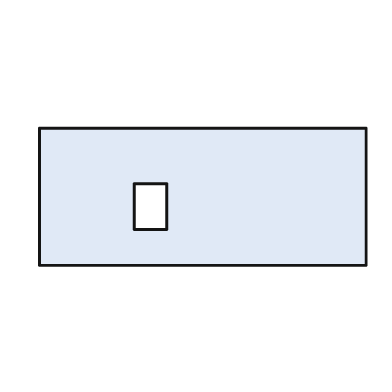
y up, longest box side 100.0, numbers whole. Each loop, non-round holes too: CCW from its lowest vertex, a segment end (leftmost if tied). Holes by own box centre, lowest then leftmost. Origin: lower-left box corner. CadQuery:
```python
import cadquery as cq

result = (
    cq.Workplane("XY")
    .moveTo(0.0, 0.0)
    .lineTo(100.0, 0.0)
    .lineTo(100.0, 42.0)
    .lineTo(0.0, 42.0)
    .close()
    .moveTo(29.0, 11.0)
    .lineTo(39.0, 11.0)
    .lineTo(39.0, 25.0)
    .lineTo(29.0, 25.0)
    .close()
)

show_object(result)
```